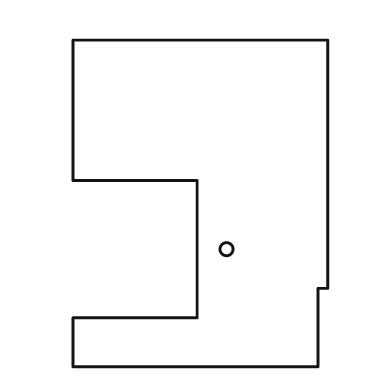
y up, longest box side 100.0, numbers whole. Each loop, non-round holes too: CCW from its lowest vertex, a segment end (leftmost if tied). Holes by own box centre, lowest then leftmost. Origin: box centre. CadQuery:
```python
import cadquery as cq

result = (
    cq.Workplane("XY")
    .moveTo(-39.0, -50.0)
    .lineTo(36.0, -50.0)
    .lineTo(36.0, -26.0)
    .lineTo(39.0, -26.0)
    .lineTo(39.0, 50.0)
    .lineTo(-39.0, 50.0)
    .lineTo(-39.0, 7.0)
    .lineTo(-1.0, 7.0)
    .lineTo(-1.0, -35.0)
    .lineTo(-39.0, -35.0)
    .close()
    .moveTo(8.0, -14.0)
    .circle(2.0)
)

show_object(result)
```